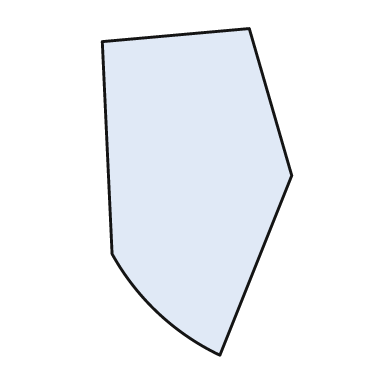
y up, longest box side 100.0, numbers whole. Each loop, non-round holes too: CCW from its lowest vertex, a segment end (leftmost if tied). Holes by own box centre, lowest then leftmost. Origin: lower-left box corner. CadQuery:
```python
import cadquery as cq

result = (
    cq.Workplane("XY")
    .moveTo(36.0, 0.0)
    .lineTo(58.0, 55.0)
    .lineTo(45.0, 100.0)
    .lineTo(0.0, 96.0)
    .lineTo(3.0, 31.0)
    .threePointArc((17.0, 13.0), (36.0, 0.0))
    .close()
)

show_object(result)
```